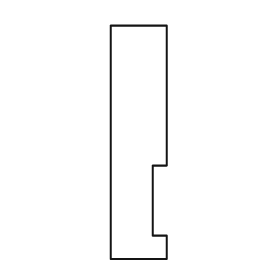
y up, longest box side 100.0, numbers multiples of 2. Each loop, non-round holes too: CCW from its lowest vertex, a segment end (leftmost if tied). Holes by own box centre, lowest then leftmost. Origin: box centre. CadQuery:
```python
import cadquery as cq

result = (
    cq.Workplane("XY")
    .moveTo(-12.0, -50.0)
    .lineTo(12.0, -50.0)
    .lineTo(12.0, -40.0)
    .lineTo(6.0, -40.0)
    .lineTo(6.0, -10.0)
    .lineTo(12.0, -10.0)
    .lineTo(12.0, 50.0)
    .lineTo(-12.0, 50.0)
    .close()
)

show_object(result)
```